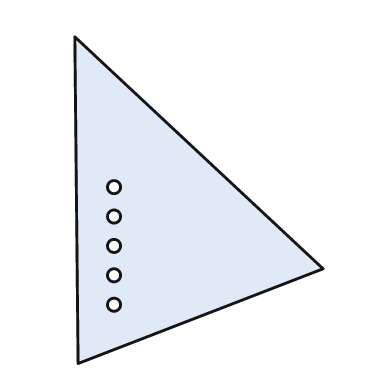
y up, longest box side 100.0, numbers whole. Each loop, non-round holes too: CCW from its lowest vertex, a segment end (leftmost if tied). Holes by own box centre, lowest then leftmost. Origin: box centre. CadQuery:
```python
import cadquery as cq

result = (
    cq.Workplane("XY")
    .moveTo(-37.0, -50.0)
    .lineTo(38.0, -21.0)
    .lineTo(-38.0, 50.0)
    .close()
    .moveTo(-26.0, -32.0)
    .circle(2.0)
    .moveTo(-26.0, -23.0)
    .circle(2.0)
    .moveTo(-26.0, -14.0)
    .circle(2.0)
    .moveTo(-26.0, -5.0)
    .circle(2.0)
    .moveTo(-26.0, 4.0)
    .circle(2.0)
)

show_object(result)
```